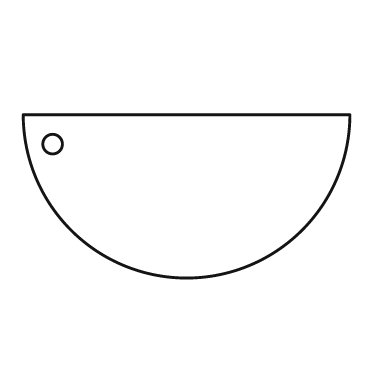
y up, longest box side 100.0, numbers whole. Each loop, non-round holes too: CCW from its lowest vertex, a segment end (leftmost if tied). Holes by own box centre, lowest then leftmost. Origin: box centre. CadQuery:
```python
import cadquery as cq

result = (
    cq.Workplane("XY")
    .moveTo(-50.0, 25.0)
    .threePointArc((0.0, -25.0), (50.0, 25.0))
    .close()
    .moveTo(-41.0, 16.0)
    .circle(3.0)
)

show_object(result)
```